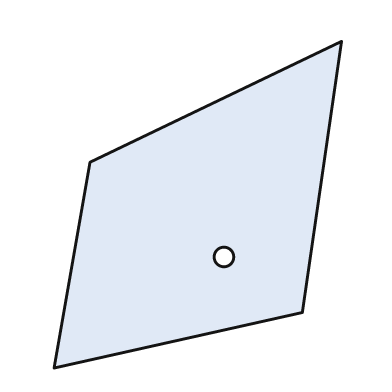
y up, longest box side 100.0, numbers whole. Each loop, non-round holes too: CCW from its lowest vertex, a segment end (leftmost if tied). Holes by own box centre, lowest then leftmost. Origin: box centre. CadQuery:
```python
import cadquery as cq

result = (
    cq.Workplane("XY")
    .moveTo(-44.0, -50.0)
    .lineTo(32.0, -33.0)
    .lineTo(44.0, 50.0)
    .lineTo(-33.0, 13.0)
    .close()
    .moveTo(8.0, -16.0)
    .circle(3.0)
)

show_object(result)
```